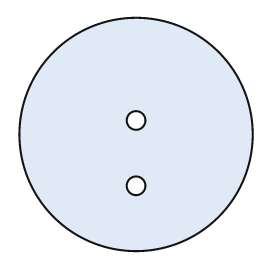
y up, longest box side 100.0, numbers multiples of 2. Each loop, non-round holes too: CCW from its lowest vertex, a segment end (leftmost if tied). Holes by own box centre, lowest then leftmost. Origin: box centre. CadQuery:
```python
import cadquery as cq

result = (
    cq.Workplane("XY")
    .moveTo(0.0, 0.0)
    .circle(50.0)
    .moveTo(0.0, -22.0)
    .circle(4.0)
    .moveTo(0.0, 6.0)
    .circle(4.0)
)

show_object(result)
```